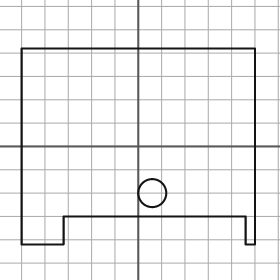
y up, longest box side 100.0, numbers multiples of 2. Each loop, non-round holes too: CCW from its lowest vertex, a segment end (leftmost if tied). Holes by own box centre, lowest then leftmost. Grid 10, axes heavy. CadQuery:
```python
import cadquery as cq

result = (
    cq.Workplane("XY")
    .moveTo(-50.0, -42.0)
    .lineTo(-32.0, -42.0)
    .lineTo(-32.0, -30.0)
    .lineTo(46.0, -30.0)
    .lineTo(46.0, -42.0)
    .lineTo(50.0, -42.0)
    .lineTo(50.0, 42.0)
    .lineTo(-50.0, 42.0)
    .close()
    .moveTo(6.0, -20.0)
    .circle(6.0)
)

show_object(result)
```